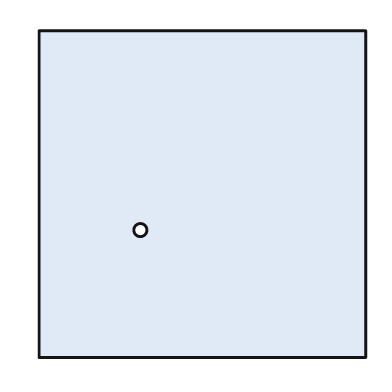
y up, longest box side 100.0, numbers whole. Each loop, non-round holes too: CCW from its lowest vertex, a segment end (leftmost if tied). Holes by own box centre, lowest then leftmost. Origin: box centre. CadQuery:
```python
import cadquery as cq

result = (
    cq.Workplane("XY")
    .moveTo(-50.0, -50.0)
    .lineTo(50.0, -50.0)
    .lineTo(50.0, 50.0)
    .lineTo(-50.0, 50.0)
    .close()
    .moveTo(-19.0, -11.0)
    .circle(2.0)
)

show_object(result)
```